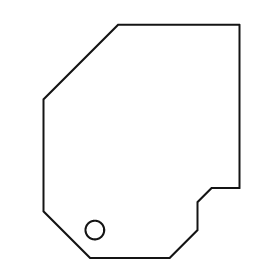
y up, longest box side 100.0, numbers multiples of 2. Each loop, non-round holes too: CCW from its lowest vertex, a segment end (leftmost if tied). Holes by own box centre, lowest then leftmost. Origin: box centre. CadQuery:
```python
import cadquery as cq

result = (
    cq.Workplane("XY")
    .moveTo(-22.0, -50.0)
    .lineTo(12.0, -50.0)
    .lineTo(24.0, -38.0)
    .lineTo(24.0, -26.0)
    .lineTo(30.0, -20.0)
    .lineTo(42.0, -20.0)
    .lineTo(42.0, 50.0)
    .lineTo(-10.0, 50.0)
    .lineTo(-42.0, 18.0)
    .lineTo(-42.0, -30.0)
    .close()
    .moveTo(-20.0, -38.0)
    .circle(4.0)
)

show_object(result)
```